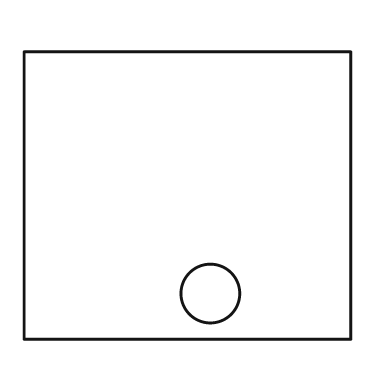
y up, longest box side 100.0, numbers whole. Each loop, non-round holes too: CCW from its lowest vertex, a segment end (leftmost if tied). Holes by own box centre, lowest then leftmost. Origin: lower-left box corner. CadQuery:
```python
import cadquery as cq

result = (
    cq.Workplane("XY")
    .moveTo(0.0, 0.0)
    .lineTo(100.0, 0.0)
    .lineTo(100.0, 88.0)
    .lineTo(0.0, 88.0)
    .close()
    .moveTo(57.0, 14.0)
    .circle(9.0)
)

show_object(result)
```